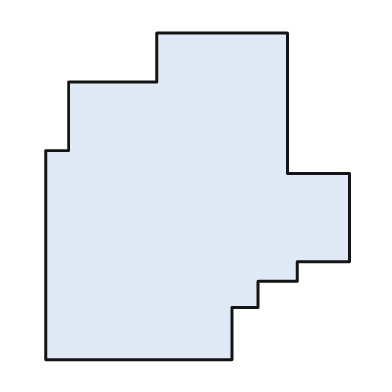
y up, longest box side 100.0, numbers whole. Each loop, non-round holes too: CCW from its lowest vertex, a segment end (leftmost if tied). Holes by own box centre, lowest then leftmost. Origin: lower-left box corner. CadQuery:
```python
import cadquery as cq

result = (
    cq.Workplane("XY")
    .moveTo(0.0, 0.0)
    .lineTo(57.0, 0.0)
    .lineTo(57.0, 16.0)
    .lineTo(65.0, 16.0)
    .lineTo(65.0, 24.0)
    .lineTo(77.0, 24.0)
    .lineTo(77.0, 30.0)
    .lineTo(93.0, 30.0)
    .lineTo(93.0, 57.0)
    .lineTo(74.0, 57.0)
    .lineTo(74.0, 100.0)
    .lineTo(34.0, 100.0)
    .lineTo(34.0, 85.0)
    .lineTo(7.0, 85.0)
    .lineTo(7.0, 64.0)
    .lineTo(0.0, 64.0)
    .close()
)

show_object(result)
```